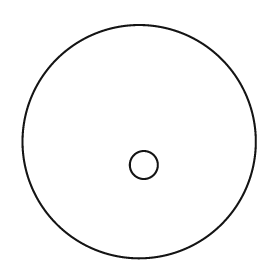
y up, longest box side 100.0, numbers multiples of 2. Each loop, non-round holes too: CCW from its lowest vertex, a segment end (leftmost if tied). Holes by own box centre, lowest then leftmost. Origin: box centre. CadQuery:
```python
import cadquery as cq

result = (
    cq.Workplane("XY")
    .moveTo(0.0, 0.0)
    .circle(50.0)
    .moveTo(2.0, -10.0)
    .circle(6.0)
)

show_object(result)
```